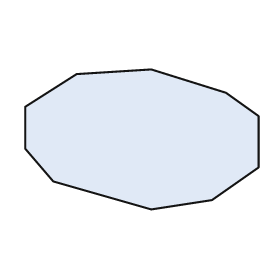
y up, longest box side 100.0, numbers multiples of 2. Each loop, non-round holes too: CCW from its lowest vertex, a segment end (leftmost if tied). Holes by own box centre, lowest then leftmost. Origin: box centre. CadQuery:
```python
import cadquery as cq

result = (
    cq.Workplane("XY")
    .moveTo(4.0, -30.0)
    .lineTo(30.0, -26.0)
    .lineTo(50.0, -12.0)
    .lineTo(50.0, 10.0)
    .lineTo(36.0, 20.0)
    .lineTo(4.0, 30.0)
    .lineTo(-28.0, 28.0)
    .lineTo(-50.0, 14.0)
    .lineTo(-50.0, -4.0)
    .lineTo(-38.0, -18.0)
    .close()
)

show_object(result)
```